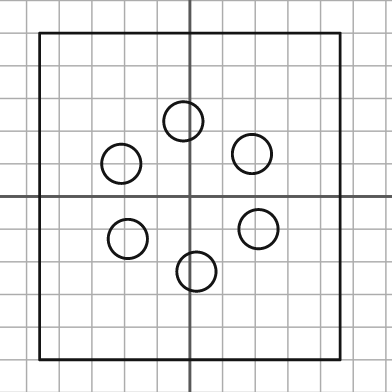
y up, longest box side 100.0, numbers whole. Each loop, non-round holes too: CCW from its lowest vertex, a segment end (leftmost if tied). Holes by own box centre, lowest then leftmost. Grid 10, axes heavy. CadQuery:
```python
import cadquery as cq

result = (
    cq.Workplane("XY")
    .moveTo(-46.0, -50.0)
    .lineTo(46.0, -50.0)
    .lineTo(46.0, 50.0)
    .lineTo(-46.0, 50.0)
    .close()
    .moveTo(2.0, -23.0)
    .circle(6.0)
    .moveTo(-19.0, -13.0)
    .circle(6.0)
    .moveTo(21.0, -10.0)
    .circle(6.0)
    .moveTo(-21.0, 10.0)
    .circle(6.0)
    .moveTo(19.0, 13.0)
    .circle(6.0)
    .moveTo(-2.0, 23.0)
    .circle(6.0)
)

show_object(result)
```